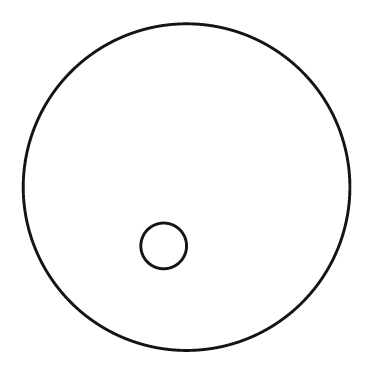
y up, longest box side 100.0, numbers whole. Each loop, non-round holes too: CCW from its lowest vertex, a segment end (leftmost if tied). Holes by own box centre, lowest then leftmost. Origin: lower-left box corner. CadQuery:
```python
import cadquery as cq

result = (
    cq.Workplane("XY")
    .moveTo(50.0, 50.0)
    .circle(50.0)
    .moveTo(43.0, 32.0)
    .circle(7.0)
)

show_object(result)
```